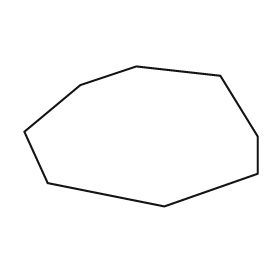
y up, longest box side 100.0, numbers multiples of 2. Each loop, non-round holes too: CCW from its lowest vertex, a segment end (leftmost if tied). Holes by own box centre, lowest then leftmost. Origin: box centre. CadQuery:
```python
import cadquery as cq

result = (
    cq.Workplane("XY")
    .moveTo(10.0, -30.0)
    .lineTo(50.0, -16.0)
    .lineTo(50.0, 0.0)
    .lineTo(34.0, 26.0)
    .lineTo(-2.0, 30.0)
    .lineTo(-26.0, 22.0)
    .lineTo(-50.0, 2.0)
    .lineTo(-40.0, -20.0)
    .close()
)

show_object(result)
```